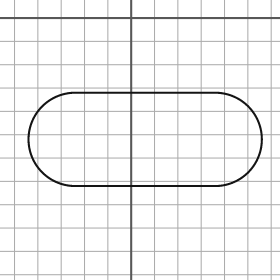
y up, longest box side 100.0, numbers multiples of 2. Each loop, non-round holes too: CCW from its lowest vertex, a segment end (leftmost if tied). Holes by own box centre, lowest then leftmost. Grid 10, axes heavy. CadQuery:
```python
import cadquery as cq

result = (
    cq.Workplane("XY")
    .moveTo(-24.0, -72.0)
    .lineTo(36.0, -72.0)
    .threePointArc((56.0, -52.0), (36.0, -32.0))
    .lineTo(-24.0, -32.0)
    .threePointArc((-44.0, -52.0), (-24.0, -72.0))
    .close()
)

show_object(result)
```